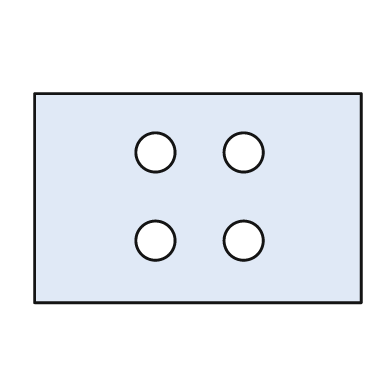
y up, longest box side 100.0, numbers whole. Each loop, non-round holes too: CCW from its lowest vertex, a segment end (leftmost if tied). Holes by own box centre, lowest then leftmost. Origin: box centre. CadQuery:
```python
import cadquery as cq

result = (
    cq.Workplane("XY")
    .moveTo(-50.0, -32.0)
    .lineTo(50.0, -32.0)
    .lineTo(50.0, 32.0)
    .lineTo(-50.0, 32.0)
    .close()
    .moveTo(-13.0, -13.0)
    .circle(6.0)
    .moveTo(14.0, -13.0)
    .circle(6.0)
    .moveTo(-13.0, 14.0)
    .circle(6.0)
    .moveTo(14.0, 14.0)
    .circle(6.0)
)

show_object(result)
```